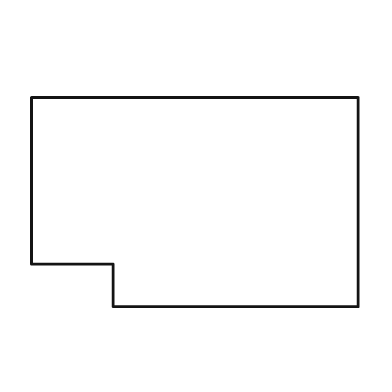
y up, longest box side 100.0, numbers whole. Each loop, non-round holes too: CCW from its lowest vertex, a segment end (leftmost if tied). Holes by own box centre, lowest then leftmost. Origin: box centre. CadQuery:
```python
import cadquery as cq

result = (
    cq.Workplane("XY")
    .moveTo(-25.0, -32.0)
    .lineTo(50.0, -32.0)
    .lineTo(50.0, 32.0)
    .lineTo(-50.0, 32.0)
    .lineTo(-50.0, -19.0)
    .lineTo(-25.0, -19.0)
    .close()
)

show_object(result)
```